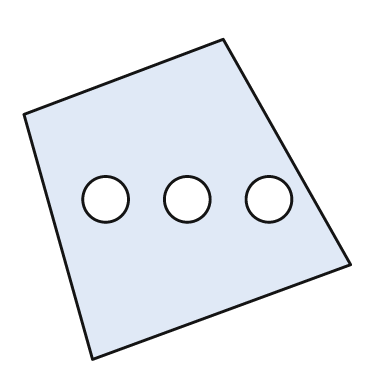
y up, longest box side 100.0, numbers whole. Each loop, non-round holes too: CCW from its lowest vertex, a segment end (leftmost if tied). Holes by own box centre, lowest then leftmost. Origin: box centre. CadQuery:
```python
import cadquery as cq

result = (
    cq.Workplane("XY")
    .moveTo(-29.0, -49.0)
    .lineTo(50.0, -20.0)
    .lineTo(11.0, 49.0)
    .lineTo(-50.0, 26.0)
    .close()
    .moveTo(-25.0, 0.0)
    .circle(7.0)
    .moveTo(0.0, 0.0)
    .circle(7.0)
    .moveTo(25.0, 0.0)
    .circle(7.0)
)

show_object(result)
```